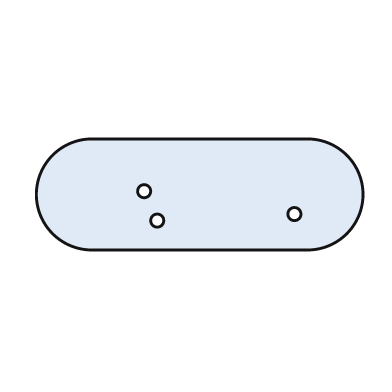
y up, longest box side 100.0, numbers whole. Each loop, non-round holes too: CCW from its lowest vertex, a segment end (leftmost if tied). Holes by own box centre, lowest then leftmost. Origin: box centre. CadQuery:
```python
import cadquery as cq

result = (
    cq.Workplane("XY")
    .moveTo(-33.0, -17.0)
    .lineTo(33.0, -17.0)
    .threePointArc((50.0, 0.0), (33.0, 17.0))
    .lineTo(-33.0, 17.0)
    .threePointArc((-50.0, 0.0), (-33.0, -17.0))
    .close()
    .moveTo(-13.0, -8.0)
    .circle(2.0)
    .moveTo(29.0, -6.0)
    .circle(2.0)
    .moveTo(-17.0, 1.0)
    .circle(2.0)
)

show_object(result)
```